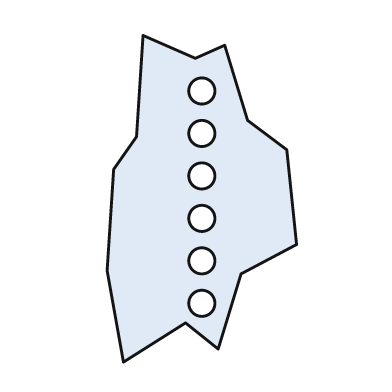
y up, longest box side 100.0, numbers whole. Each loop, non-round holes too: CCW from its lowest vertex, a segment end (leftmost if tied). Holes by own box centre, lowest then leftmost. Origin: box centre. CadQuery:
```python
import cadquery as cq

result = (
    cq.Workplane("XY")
    .moveTo(-24.0, -50.0)
    .lineTo(-5.0, -38.0)
    .lineTo(5.0, -46.0)
    .lineTo(12.0, -23.0)
    .lineTo(29.0, -14.0)
    .lineTo(26.0, 15.0)
    .lineTo(14.0, 24.0)
    .lineTo(7.0, 47.0)
    .lineTo(-2.0, 43.0)
    .lineTo(-18.0, 50.0)
    .lineTo(-20.0, 19.0)
    .lineTo(-27.0, 9.0)
    .lineTo(-29.0, -22.0)
    .close()
    .moveTo(0.0, -32.0)
    .circle(4.0)
    .moveTo(0.0, -19.0)
    .circle(4.0)
    .moveTo(0.0, -6.0)
    .circle(4.0)
    .moveTo(0.0, 7.0)
    .circle(4.0)
    .moveTo(0.0, 20.0)
    .circle(4.0)
    .moveTo(0.0, 33.0)
    .circle(4.0)
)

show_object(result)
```